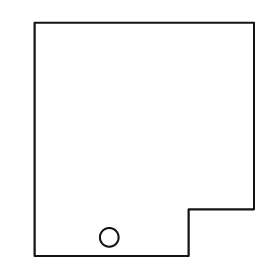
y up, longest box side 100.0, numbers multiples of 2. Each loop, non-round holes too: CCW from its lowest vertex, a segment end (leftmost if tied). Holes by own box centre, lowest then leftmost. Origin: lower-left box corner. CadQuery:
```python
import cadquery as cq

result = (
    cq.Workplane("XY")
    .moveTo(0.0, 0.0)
    .lineTo(66.0, 0.0)
    .lineTo(66.0, 20.0)
    .lineTo(94.0, 20.0)
    .lineTo(94.0, 100.0)
    .lineTo(0.0, 100.0)
    .close()
    .moveTo(32.0, 8.0)
    .circle(4.0)
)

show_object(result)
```